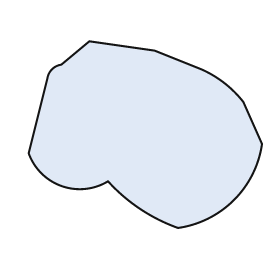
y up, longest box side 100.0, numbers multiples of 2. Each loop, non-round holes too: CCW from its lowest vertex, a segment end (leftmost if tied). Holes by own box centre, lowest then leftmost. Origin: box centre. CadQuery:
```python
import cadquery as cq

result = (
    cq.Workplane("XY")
    .moveTo(14.0, -40.0)
    .threePointArc((38.0, -28.0), (50.0, -4.0))
    .lineTo(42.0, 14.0)
    .threePointArc((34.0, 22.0), (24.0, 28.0))
    .lineTo(4.0, 36.0)
    .lineTo(-24.0, 40.0)
    .lineTo(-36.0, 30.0)
    .threePointArc((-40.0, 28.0), (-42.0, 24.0))
    .lineTo(-50.0, -8.0)
    .threePointArc((-36.0, -22.0), (-16.0, -20.0))
    .threePointArc((-2.0, -32.0), (14.0, -40.0))
    .close()
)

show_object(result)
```